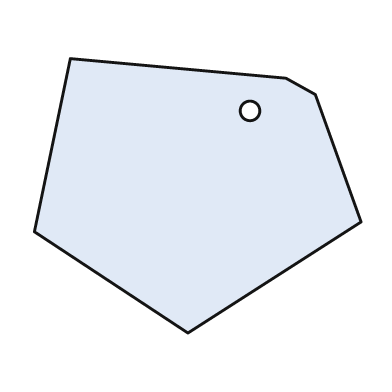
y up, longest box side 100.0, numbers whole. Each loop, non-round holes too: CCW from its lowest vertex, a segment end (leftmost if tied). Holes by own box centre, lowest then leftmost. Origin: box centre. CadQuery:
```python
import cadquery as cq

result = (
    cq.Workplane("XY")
    .moveTo(-3.0, -42.0)
    .lineTo(50.0, -8.0)
    .lineTo(36.0, 31.0)
    .lineTo(27.0, 36.0)
    .lineTo(-39.0, 42.0)
    .lineTo(-50.0, -11.0)
    .close()
    .moveTo(16.0, 26.0)
    .circle(3.0)
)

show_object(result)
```